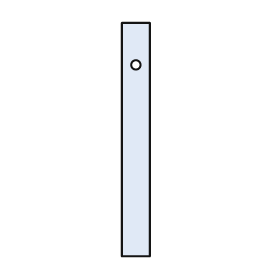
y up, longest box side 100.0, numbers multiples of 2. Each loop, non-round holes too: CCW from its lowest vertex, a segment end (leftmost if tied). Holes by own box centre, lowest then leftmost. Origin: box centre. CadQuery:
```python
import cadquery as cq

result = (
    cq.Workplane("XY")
    .moveTo(-6.0, -50.0)
    .lineTo(6.0, -50.0)
    .lineTo(6.0, 50.0)
    .lineTo(-6.0, 50.0)
    .close()
    .moveTo(0.0, 32.0)
    .circle(2.0)
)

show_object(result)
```